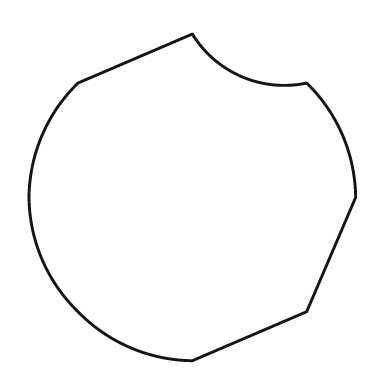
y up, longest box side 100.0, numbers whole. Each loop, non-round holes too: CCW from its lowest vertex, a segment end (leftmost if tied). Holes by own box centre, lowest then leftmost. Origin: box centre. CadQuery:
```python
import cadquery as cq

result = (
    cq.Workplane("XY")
    .moveTo(0.0, -50.0)
    .lineTo(35.0, -35.0)
    .lineTo(50.0, 0.0)
    .threePointArc((46.0, 19.0), (35.0, 35.0))
    .threePointArc((15.0, 37.0), (0.0, 50.0))
    .lineTo(-35.0, 35.0)
    .threePointArc((-46.0, 19.0), (-50.0, 0.0))
    .threePointArc((-46.0, -19.0), (-35.0, -35.0))
    .threePointArc((-19.0, -46.0), (0.0, -50.0))
    .close()
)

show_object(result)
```